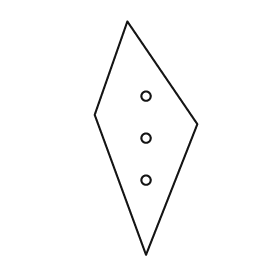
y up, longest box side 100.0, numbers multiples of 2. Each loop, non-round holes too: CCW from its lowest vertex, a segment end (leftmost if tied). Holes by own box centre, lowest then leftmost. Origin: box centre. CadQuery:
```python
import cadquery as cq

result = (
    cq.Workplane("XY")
    .moveTo(0.0, -50.0)
    .lineTo(22.0, 6.0)
    .lineTo(-8.0, 50.0)
    .lineTo(-22.0, 10.0)
    .close()
    .moveTo(0.0, -18.0)
    .circle(2.0)
    .moveTo(0.0, 0.0)
    .circle(2.0)
    .moveTo(0.0, 18.0)
    .circle(2.0)
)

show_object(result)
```